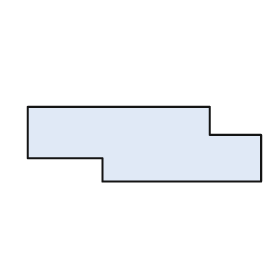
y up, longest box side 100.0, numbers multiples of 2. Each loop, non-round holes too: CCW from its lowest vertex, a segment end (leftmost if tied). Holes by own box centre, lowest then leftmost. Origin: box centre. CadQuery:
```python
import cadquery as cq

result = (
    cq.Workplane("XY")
    .moveTo(-18.0, -16.0)
    .lineTo(50.0, -16.0)
    .lineTo(50.0, 4.0)
    .lineTo(28.0, 4.0)
    .lineTo(28.0, 16.0)
    .lineTo(-50.0, 16.0)
    .lineTo(-50.0, -6.0)
    .lineTo(-18.0, -6.0)
    .close()
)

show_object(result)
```